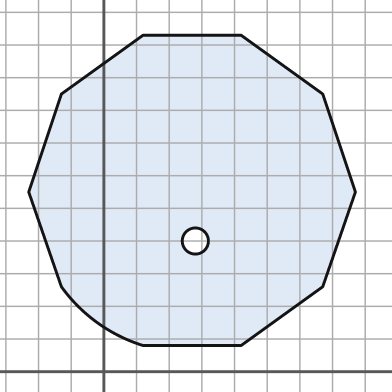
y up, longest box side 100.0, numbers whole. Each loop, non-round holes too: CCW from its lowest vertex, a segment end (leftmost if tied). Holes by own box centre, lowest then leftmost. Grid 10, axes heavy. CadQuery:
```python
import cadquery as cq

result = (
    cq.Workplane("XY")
    .moveTo(12.0, 8.0)
    .lineTo(42.0, 8.0)
    .lineTo(67.0, 26.0)
    .lineTo(77.0, 55.0)
    .lineTo(67.0, 85.0)
    .lineTo(42.0, 103.0)
    .lineTo(12.0, 103.0)
    .lineTo(-13.0, 85.0)
    .lineTo(-23.0, 55.0)
    .lineTo(-13.0, 26.0)
    .threePointArc((-2.0, 15.0), (12.0, 8.0))
    .close()
    .moveTo(28.0, 40.0)
    .circle(4.0)
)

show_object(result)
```